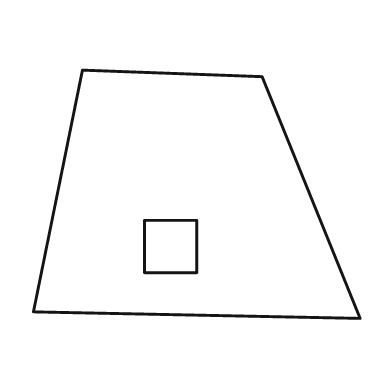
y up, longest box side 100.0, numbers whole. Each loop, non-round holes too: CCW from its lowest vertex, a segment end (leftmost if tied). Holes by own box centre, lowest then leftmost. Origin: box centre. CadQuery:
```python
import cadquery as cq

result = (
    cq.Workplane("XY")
    .moveTo(50.0, -38.0)
    .lineTo(20.0, 36.0)
    .lineTo(-35.0, 38.0)
    .lineTo(-50.0, -36.0)
    .close()
    .moveTo(-16.0, -24.0)
    .lineTo(0.0, -24.0)
    .lineTo(0.0, -8.0)
    .lineTo(-16.0, -8.0)
    .close()
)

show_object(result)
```